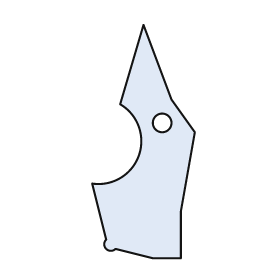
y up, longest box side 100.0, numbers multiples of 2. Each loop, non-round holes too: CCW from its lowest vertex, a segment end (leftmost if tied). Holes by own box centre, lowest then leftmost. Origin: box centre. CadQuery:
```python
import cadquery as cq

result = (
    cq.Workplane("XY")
    .moveTo(4.0, -50.0)
    .lineTo(16.0, -50.0)
    .lineTo(16.0, -30.0)
    .lineTo(22.0, 4.0)
    .lineTo(12.0, 18.0)
    .lineTo(0.0, 50.0)
    .lineTo(-10.0, 16.0)
    .threePointArc((-2.0, -6.0), (-22.0, -18.0))
    .lineTo(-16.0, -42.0)
    .threePointArc((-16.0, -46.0), (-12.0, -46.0))
    .close()
    .moveTo(8.0, 8.0)
    .circle(4.0)
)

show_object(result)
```